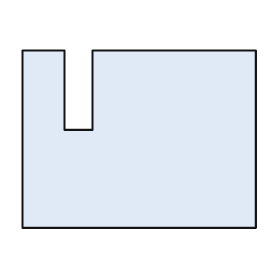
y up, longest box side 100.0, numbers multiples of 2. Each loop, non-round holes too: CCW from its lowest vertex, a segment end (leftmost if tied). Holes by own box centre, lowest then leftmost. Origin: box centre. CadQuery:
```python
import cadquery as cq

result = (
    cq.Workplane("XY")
    .moveTo(-50.0, -38.0)
    .lineTo(50.0, -38.0)
    .lineTo(50.0, 38.0)
    .lineTo(-20.0, 38.0)
    .lineTo(-20.0, 4.0)
    .lineTo(-32.0, 4.0)
    .lineTo(-32.0, 38.0)
    .lineTo(-50.0, 38.0)
    .close()
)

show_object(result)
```